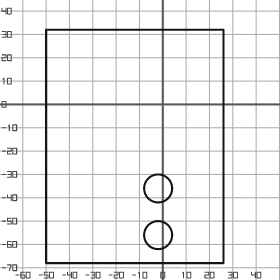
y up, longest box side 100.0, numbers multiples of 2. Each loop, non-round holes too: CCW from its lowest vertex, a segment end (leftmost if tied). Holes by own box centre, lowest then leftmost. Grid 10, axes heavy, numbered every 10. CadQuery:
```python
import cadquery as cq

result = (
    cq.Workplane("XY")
    .moveTo(-50.0, -68.0)
    .lineTo(26.0, -68.0)
    .lineTo(26.0, 32.0)
    .lineTo(-50.0, 32.0)
    .close()
    .moveTo(-2.0, -56.0)
    .circle(6.0)
    .moveTo(-2.0, -36.0)
    .circle(6.0)
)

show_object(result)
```